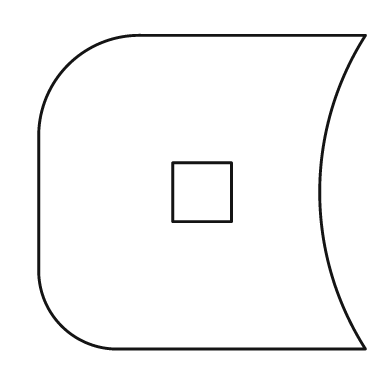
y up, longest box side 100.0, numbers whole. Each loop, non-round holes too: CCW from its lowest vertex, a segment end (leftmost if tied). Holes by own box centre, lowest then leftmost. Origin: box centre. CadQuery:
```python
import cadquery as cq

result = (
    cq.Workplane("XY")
    .moveTo(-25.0, -48.0)
    .lineTo(50.0, -48.0)
    .threePointArc((36.0, 0.0), (50.0, 48.0))
    .lineTo(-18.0, 48.0)
    .threePointArc((-41.0, 39.0), (-50.0, 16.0))
    .lineTo(-50.0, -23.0)
    .threePointArc((-43.0, -41.0), (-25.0, -48.0))
    .close()
    .moveTo(-9.0, -9.0)
    .lineTo(9.0, -9.0)
    .lineTo(9.0, 9.0)
    .lineTo(-9.0, 9.0)
    .close()
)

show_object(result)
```